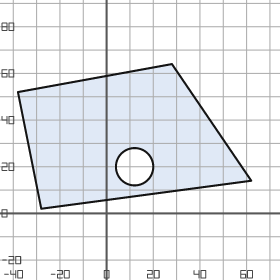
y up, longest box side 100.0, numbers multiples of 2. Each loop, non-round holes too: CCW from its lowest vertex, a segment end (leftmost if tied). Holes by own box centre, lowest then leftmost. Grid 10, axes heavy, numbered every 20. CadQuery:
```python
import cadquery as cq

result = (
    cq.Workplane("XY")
    .moveTo(-28.0, 2.0)
    .lineTo(62.0, 14.0)
    .lineTo(28.0, 64.0)
    .lineTo(-38.0, 52.0)
    .close()
    .moveTo(12.0, 20.0)
    .circle(8.0)
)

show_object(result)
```